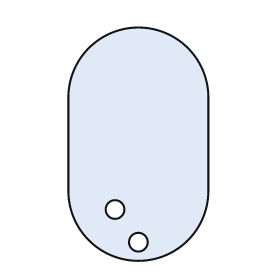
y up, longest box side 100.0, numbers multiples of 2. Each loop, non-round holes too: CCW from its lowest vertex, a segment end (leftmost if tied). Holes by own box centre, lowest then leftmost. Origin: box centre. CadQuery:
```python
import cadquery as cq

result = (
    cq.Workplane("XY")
    .moveTo(-30.0, -20.0)
    .threePointArc((0.0, -50.0), (30.0, -20.0))
    .lineTo(30.0, 20.0)
    .threePointArc((0.0, 50.0), (-30.0, 20.0))
    .close()
    .moveTo(0.0, -42.0)
    .circle(4.0)
    .moveTo(-10.0, -28.0)
    .circle(4.0)
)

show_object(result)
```